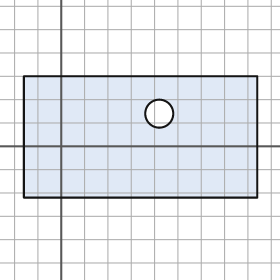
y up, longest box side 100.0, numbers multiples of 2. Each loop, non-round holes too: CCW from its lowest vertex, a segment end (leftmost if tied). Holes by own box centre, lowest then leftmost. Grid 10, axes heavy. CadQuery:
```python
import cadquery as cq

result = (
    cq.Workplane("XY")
    .moveTo(-16.0, -22.0)
    .lineTo(84.0, -22.0)
    .lineTo(84.0, 30.0)
    .lineTo(-16.0, 30.0)
    .close()
    .moveTo(42.0, 14.0)
    .circle(6.0)
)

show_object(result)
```